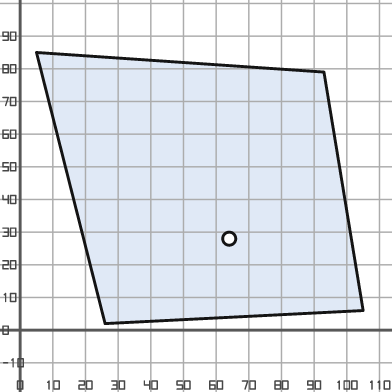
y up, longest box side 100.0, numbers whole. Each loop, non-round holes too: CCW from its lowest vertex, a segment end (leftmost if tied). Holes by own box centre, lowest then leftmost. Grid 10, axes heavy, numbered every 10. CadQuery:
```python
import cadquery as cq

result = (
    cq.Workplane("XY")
    .moveTo(26.0, 2.0)
    .lineTo(105.0, 6.0)
    .lineTo(93.0, 79.0)
    .lineTo(5.0, 85.0)
    .close()
    .moveTo(64.0, 28.0)
    .circle(2.0)
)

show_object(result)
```